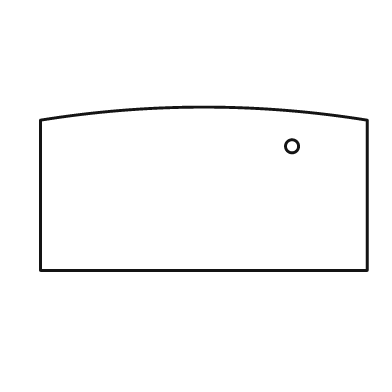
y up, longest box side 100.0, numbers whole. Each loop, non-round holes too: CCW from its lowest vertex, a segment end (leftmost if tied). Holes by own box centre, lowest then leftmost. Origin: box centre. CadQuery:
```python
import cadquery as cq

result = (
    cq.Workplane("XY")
    .moveTo(-50.0, -25.0)
    .lineTo(50.0, -25.0)
    .lineTo(50.0, 21.0)
    .threePointArc((0.0, 25.0), (-50.0, 21.0))
    .close()
    .moveTo(27.0, 13.0)
    .circle(2.0)
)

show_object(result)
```